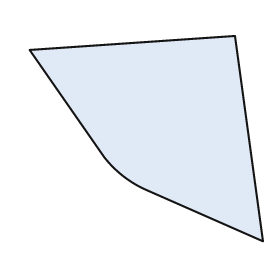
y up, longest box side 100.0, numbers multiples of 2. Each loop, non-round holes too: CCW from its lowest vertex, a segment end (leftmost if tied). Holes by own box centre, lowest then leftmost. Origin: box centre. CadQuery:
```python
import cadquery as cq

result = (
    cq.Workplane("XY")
    .moveTo(50.0, -44.0)
    .lineTo(38.0, 44.0)
    .lineTo(-50.0, 38.0)
    .lineTo(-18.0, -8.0)
    .threePointArc((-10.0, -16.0), (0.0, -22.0))
    .close()
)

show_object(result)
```